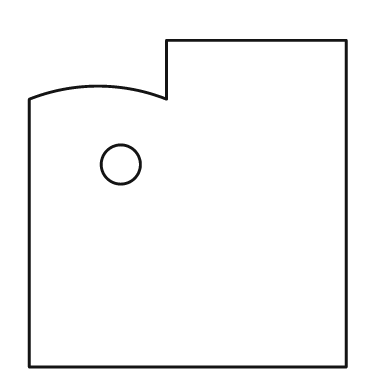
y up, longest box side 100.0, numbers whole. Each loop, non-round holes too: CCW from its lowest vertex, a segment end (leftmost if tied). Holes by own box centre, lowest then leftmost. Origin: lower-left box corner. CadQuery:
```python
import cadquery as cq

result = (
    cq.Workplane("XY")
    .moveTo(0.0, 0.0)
    .lineTo(97.0, 0.0)
    .lineTo(97.0, 100.0)
    .lineTo(42.0, 100.0)
    .lineTo(42.0, 82.0)
    .threePointArc((21.0, 86.0), (0.0, 82.0))
    .close()
    .moveTo(28.0, 62.0)
    .circle(6.0)
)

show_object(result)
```